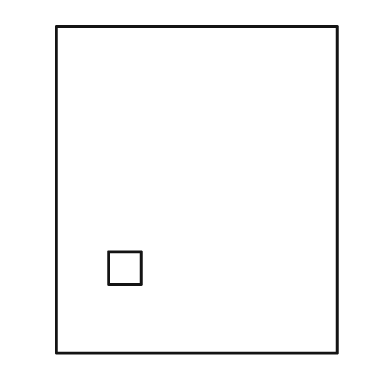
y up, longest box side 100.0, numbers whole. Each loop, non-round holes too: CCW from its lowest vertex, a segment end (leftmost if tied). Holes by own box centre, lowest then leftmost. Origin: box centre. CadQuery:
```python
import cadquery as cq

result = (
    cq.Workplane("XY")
    .moveTo(-43.0, -50.0)
    .lineTo(43.0, -50.0)
    .lineTo(43.0, 50.0)
    .lineTo(-43.0, 50.0)
    .close()
    .moveTo(-27.0, -29.0)
    .lineTo(-17.0, -29.0)
    .lineTo(-17.0, -19.0)
    .lineTo(-27.0, -19.0)
    .close()
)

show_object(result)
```